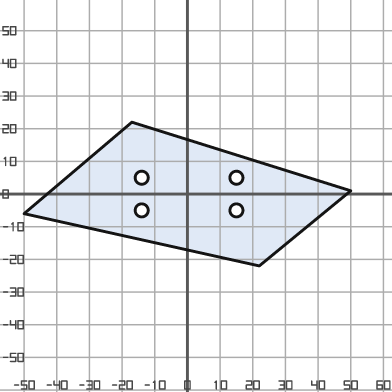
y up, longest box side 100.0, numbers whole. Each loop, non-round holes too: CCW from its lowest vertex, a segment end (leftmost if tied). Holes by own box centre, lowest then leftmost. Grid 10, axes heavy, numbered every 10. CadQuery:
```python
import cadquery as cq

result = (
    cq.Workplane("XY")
    .moveTo(22.0, -22.0)
    .lineTo(50.0, 1.0)
    .lineTo(-17.0, 22.0)
    .lineTo(-50.0, -6.0)
    .close()
    .moveTo(-14.0, -5.0)
    .circle(2.0)
    .moveTo(15.0, -5.0)
    .circle(2.0)
    .moveTo(-14.0, 5.0)
    .circle(2.0)
    .moveTo(15.0, 5.0)
    .circle(2.0)
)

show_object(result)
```